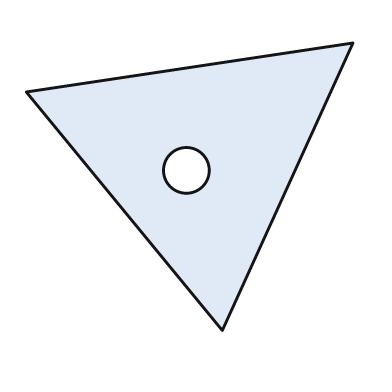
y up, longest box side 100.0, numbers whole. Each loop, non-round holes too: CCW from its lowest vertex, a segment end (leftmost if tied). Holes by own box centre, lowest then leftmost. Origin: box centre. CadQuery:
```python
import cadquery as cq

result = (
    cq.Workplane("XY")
    .moveTo(10.0, -44.0)
    .lineTo(50.0, 44.0)
    .lineTo(-50.0, 29.0)
    .close()
    .moveTo(-1.0, 5.0)
    .circle(7.0)
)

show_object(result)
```